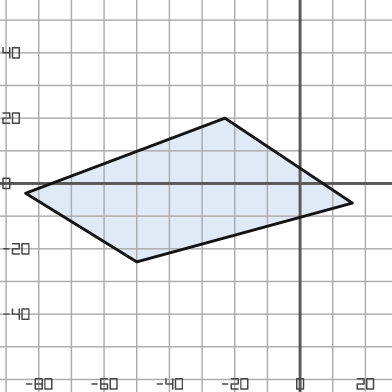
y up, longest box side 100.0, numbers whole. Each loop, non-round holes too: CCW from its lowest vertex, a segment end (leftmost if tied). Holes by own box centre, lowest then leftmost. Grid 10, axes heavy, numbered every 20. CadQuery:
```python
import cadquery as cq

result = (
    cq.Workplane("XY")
    .moveTo(-50.0, -24.0)
    .lineTo(16.0, -6.0)
    .lineTo(-23.0, 20.0)
    .lineTo(-84.0, -3.0)
    .close()
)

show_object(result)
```